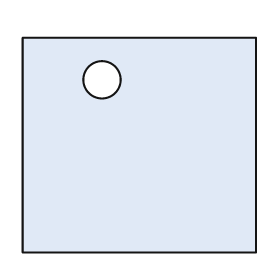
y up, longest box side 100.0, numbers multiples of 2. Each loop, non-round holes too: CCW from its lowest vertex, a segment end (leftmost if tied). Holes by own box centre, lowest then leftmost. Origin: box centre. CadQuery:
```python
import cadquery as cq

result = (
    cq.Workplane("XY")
    .moveTo(-50.0, -46.0)
    .lineTo(50.0, -46.0)
    .lineTo(50.0, 46.0)
    .lineTo(-50.0, 46.0)
    .close()
    .moveTo(-16.0, 28.0)
    .circle(8.0)
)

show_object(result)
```